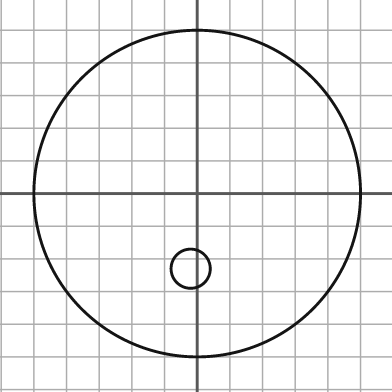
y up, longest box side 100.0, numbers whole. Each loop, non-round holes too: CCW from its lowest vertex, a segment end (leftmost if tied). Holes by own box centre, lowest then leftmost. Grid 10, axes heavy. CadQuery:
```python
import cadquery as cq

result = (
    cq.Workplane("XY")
    .moveTo(0.0, 0.0)
    .circle(50.0)
    .moveTo(-2.0, -23.0)
    .circle(6.0)
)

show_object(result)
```